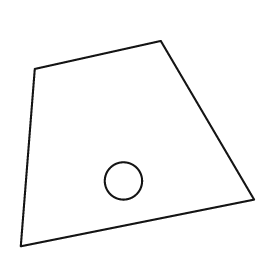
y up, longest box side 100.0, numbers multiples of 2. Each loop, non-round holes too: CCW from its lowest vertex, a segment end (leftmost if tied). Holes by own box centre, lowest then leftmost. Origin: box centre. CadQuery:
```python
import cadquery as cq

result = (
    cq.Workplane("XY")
    .moveTo(-50.0, -44.0)
    .lineTo(50.0, -24.0)
    .lineTo(10.0, 44.0)
    .lineTo(-44.0, 32.0)
    .close()
    .moveTo(-6.0, -16.0)
    .circle(8.0)
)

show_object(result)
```